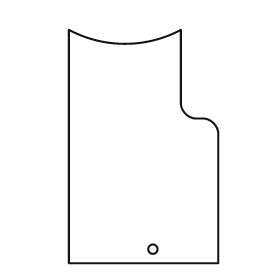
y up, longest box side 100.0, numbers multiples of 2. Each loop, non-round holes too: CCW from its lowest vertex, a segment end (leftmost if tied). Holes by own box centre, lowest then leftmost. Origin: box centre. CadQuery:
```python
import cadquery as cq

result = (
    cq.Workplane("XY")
    .moveTo(-32.0, -50.0)
    .lineTo(32.0, -50.0)
    .lineTo(32.0, 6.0)
    .threePointArc((30.0, 10.0), (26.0, 12.0))
    .lineTo(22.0, 12.0)
    .threePointArc((18.0, 14.0), (16.0, 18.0))
    .lineTo(16.0, 50.0)
    .threePointArc((-8.0, 44.0), (-32.0, 50.0))
    .close()
    .moveTo(4.0, -44.0)
    .circle(2.0)
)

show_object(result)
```